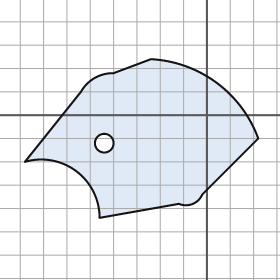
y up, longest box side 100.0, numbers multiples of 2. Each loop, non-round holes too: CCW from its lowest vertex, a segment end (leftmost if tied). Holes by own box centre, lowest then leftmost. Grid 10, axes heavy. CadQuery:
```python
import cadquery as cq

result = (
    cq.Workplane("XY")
    .moveTo(-46.0, -44.0)
    .lineTo(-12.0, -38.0)
    .threePointArc((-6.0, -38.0), (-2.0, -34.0))
    .lineTo(22.0, -10.0)
    .threePointArc((4.0, 14.0), (-24.0, 24.0))
    .lineTo(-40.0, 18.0)
    .threePointArc((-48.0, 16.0), (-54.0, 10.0))
    .lineTo(-78.0, -20.0)
    .threePointArc((-56.0, -24.0), (-46.0, -44.0))
    .close()
    .moveTo(-44.0, -12.0)
    .circle(4.0)
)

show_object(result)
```